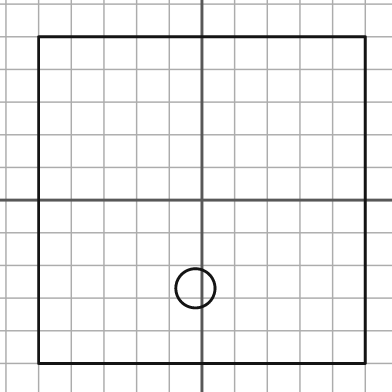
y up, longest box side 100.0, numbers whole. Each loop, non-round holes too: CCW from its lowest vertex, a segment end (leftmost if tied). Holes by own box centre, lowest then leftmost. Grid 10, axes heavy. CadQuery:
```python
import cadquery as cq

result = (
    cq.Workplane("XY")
    .moveTo(-50.0, -50.0)
    .lineTo(50.0, -50.0)
    .lineTo(50.0, 50.0)
    .lineTo(-50.0, 50.0)
    .close()
    .moveTo(-2.0, -27.0)
    .circle(6.0)
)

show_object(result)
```